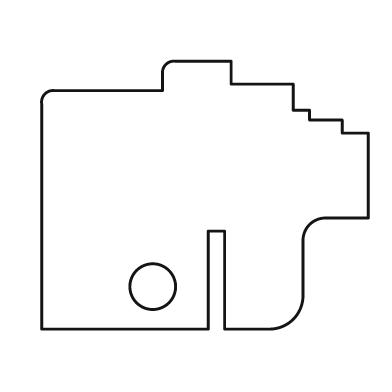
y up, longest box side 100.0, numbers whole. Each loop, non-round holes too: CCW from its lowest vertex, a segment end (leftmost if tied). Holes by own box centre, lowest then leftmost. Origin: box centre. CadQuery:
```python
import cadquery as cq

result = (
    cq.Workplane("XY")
    .moveTo(-50.0, -41.0)
    .lineTo(1.0, -41.0)
    .lineTo(1.0, -11.0)
    .lineTo(6.0, -11.0)
    .lineTo(6.0, -41.0)
    .lineTo(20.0, -41.0)
    .threePointArc((27.0, -38.0), (30.0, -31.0))
    .lineTo(30.0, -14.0)
    .threePointArc((32.0, -9.0), (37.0, -7.0))
    .lineTo(50.0, -7.0)
    .lineTo(50.0, 19.0)
    .lineTo(42.0, 19.0)
    .lineTo(42.0, 23.0)
    .lineTo(32.0, 23.0)
    .lineTo(32.0, 26.0)
    .lineTo(27.0, 26.0)
    .lineTo(27.0, 34.0)
    .lineTo(8.0, 34.0)
    .lineTo(8.0, 41.0)
    .lineTo(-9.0, 41.0)
    .threePointArc((-12.0, 40.0), (-13.0, 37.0))
    .lineTo(-13.0, 32.0)
    .lineTo(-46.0, 32.0)
    .threePointArc((-49.0, 31.0), (-50.0, 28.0))
    .close()
    .moveTo(-16.0, -28.0)
    .circle(7.0)
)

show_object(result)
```